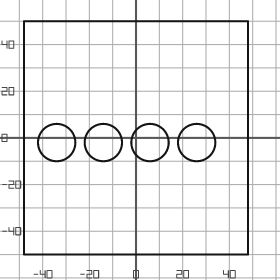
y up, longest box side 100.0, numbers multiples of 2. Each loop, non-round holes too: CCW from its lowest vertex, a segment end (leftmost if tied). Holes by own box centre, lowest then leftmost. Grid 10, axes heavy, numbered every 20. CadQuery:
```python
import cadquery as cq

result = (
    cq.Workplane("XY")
    .moveTo(-48.0, -50.0)
    .lineTo(48.0, -50.0)
    .lineTo(48.0, 50.0)
    .lineTo(-48.0, 50.0)
    .close()
    .moveTo(-34.0, -2.0)
    .circle(8.0)
    .moveTo(-14.0, -2.0)
    .circle(8.0)
    .moveTo(6.0, -2.0)
    .circle(8.0)
    .moveTo(26.0, -2.0)
    .circle(8.0)
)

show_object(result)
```